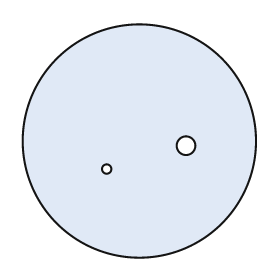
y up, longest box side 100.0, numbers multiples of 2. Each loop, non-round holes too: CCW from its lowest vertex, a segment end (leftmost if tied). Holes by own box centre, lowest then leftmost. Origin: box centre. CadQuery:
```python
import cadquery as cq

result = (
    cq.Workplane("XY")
    .moveTo(0.0, 0.0)
    .circle(50.0)
    .moveTo(-14.0, -12.0)
    .circle(2.0)
    .moveTo(20.0, -2.0)
    .circle(4.0)
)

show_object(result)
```